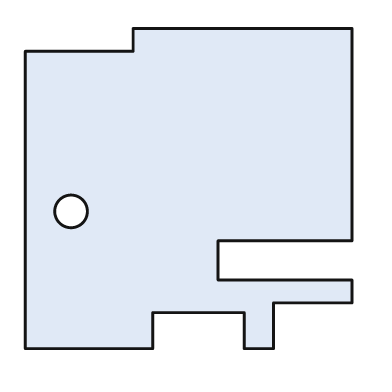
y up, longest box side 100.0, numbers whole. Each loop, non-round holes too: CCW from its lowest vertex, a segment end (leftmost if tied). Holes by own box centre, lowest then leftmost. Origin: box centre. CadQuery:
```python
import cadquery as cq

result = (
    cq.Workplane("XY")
    .moveTo(-50.0, -49.0)
    .lineTo(-11.0, -49.0)
    .lineTo(-11.0, -38.0)
    .lineTo(17.0, -38.0)
    .lineTo(17.0, -49.0)
    .lineTo(26.0, -49.0)
    .lineTo(26.0, -35.0)
    .lineTo(50.0, -35.0)
    .lineTo(50.0, -28.0)
    .lineTo(9.0, -28.0)
    .lineTo(9.0, -16.0)
    .lineTo(50.0, -16.0)
    .lineTo(50.0, 49.0)
    .lineTo(-17.0, 49.0)
    .lineTo(-17.0, 42.0)
    .lineTo(-50.0, 42.0)
    .close()
    .moveTo(-36.0, -7.0)
    .circle(5.0)
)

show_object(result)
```